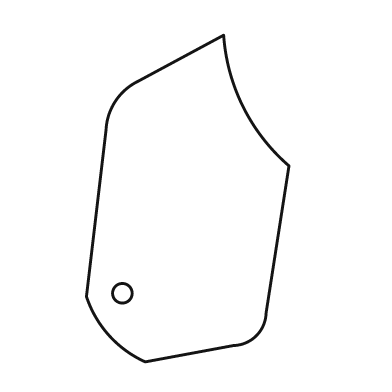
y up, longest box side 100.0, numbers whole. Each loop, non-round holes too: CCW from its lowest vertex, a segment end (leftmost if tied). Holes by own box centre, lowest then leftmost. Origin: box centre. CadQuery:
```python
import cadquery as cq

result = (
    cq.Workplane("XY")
    .moveTo(-13.0, -50.0)
    .lineTo(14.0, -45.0)
    .threePointArc((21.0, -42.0), (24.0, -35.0))
    .lineTo(31.0, 10.0)
    .threePointArc((17.0, 28.0), (11.0, 50.0))
    .lineTo(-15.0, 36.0)
    .threePointArc((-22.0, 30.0), (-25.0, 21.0))
    .lineTo(-31.0, -30.0)
    .threePointArc((-24.0, -42.0), (-13.0, -50.0))
    .close()
    .moveTo(-20.0, -29.0)
    .circle(3.0)
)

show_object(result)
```